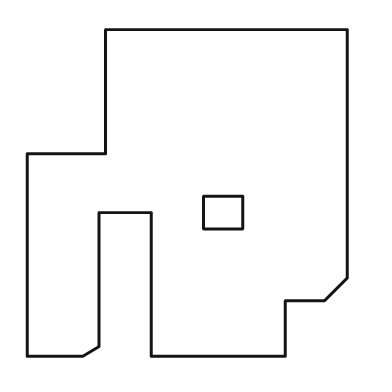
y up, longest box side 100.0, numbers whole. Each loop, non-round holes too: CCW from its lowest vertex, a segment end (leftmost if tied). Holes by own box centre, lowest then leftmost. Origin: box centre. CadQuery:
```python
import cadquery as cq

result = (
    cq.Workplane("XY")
    .moveTo(-49.0, -50.0)
    .lineTo(-32.0, -50.0)
    .lineTo(-27.0, -47.0)
    .lineTo(-27.0, -6.0)
    .lineTo(-11.0, -6.0)
    .lineTo(-11.0, -50.0)
    .lineTo(30.0, -50.0)
    .lineTo(30.0, -33.0)
    .lineTo(42.0, -33.0)
    .lineTo(49.0, -26.0)
    .lineTo(49.0, 50.0)
    .lineTo(-25.0, 50.0)
    .lineTo(-25.0, 12.0)
    .lineTo(-49.0, 12.0)
    .close()
    .moveTo(5.0, -11.0)
    .lineTo(17.0, -11.0)
    .lineTo(17.0, -1.0)
    .lineTo(5.0, -1.0)
    .close()
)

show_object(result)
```